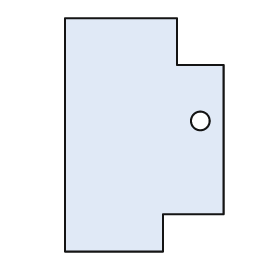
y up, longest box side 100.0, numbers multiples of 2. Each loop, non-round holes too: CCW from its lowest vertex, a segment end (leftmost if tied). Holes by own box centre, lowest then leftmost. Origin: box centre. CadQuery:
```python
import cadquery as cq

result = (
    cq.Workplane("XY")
    .moveTo(-34.0, -50.0)
    .lineTo(8.0, -50.0)
    .lineTo(8.0, -34.0)
    .lineTo(34.0, -34.0)
    .lineTo(34.0, 30.0)
    .lineTo(14.0, 30.0)
    .lineTo(14.0, 50.0)
    .lineTo(-34.0, 50.0)
    .close()
    .moveTo(24.0, 6.0)
    .circle(4.0)
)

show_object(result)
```